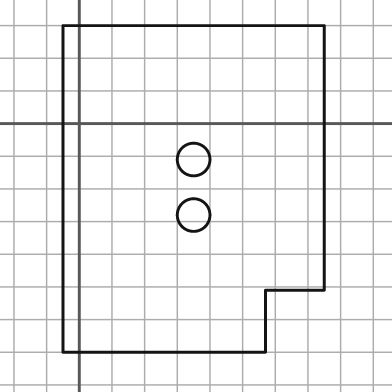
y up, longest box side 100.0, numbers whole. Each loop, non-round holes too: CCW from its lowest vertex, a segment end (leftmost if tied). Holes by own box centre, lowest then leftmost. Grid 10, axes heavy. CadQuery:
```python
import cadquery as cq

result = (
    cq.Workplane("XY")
    .moveTo(-5.0, -70.0)
    .lineTo(57.0, -70.0)
    .lineTo(57.0, -51.0)
    .lineTo(75.0, -51.0)
    .lineTo(75.0, 30.0)
    .lineTo(-5.0, 30.0)
    .close()
    .moveTo(35.0, -28.0)
    .circle(5.0)
    .moveTo(35.0, -11.0)
    .circle(5.0)
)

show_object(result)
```